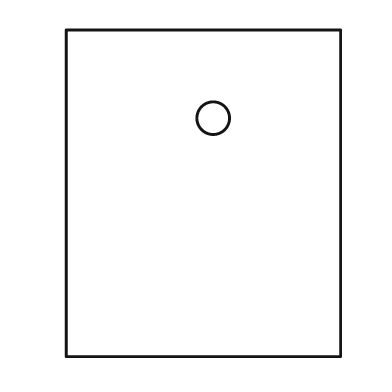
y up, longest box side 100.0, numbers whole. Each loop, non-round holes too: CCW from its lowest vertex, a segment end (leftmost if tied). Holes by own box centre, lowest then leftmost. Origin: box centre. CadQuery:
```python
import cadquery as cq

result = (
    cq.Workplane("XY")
    .moveTo(-42.0, -50.0)
    .lineTo(42.0, -50.0)
    .lineTo(42.0, 50.0)
    .lineTo(-42.0, 50.0)
    .close()
    .moveTo(3.0, 23.0)
    .circle(5.0)
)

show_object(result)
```